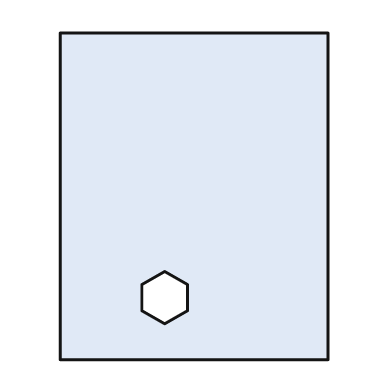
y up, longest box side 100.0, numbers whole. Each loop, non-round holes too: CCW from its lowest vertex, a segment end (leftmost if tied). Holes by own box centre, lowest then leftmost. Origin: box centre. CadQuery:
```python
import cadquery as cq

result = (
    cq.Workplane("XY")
    .moveTo(-41.0, -50.0)
    .lineTo(41.0, -50.0)
    .lineTo(41.0, 50.0)
    .lineTo(-41.0, 50.0)
    .close()
    .moveTo(-9.0, -39.0)
    .lineTo(-2.0, -35.0)
    .lineTo(-2.0, -27.0)
    .lineTo(-9.0, -23.0)
    .lineTo(-16.0, -27.0)
    .lineTo(-16.0, -35.0)
    .close()
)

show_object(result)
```